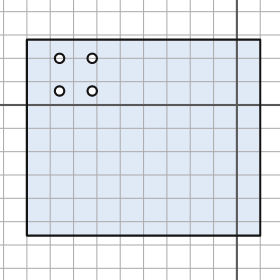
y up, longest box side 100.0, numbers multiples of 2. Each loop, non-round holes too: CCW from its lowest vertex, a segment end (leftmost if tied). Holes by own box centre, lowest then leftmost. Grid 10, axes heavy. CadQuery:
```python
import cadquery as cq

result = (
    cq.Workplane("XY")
    .moveTo(-90.0, -56.0)
    .lineTo(10.0, -56.0)
    .lineTo(10.0, 28.0)
    .lineTo(-90.0, 28.0)
    .close()
    .moveTo(-76.0, 6.0)
    .circle(2.0)
    .moveTo(-62.0, 6.0)
    .circle(2.0)
    .moveTo(-76.0, 20.0)
    .circle(2.0)
    .moveTo(-62.0, 20.0)
    .circle(2.0)
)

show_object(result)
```